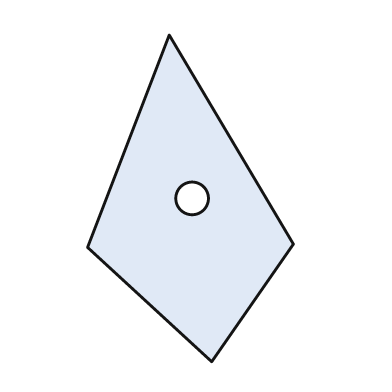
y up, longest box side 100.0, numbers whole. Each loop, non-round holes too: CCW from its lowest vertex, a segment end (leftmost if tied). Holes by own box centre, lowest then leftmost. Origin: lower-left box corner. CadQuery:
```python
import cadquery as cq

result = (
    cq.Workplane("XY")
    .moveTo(38.0, 0.0)
    .lineTo(63.0, 36.0)
    .lineTo(25.0, 100.0)
    .lineTo(0.0, 35.0)
    .close()
    .moveTo(32.0, 50.0)
    .circle(5.0)
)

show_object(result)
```